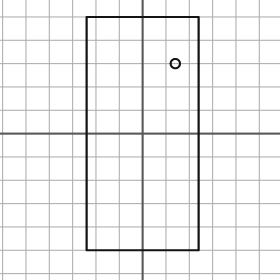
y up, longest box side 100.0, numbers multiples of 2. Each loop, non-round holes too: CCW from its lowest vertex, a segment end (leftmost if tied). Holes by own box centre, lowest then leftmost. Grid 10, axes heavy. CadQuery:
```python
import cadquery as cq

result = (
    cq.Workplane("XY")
    .moveTo(-24.0, -50.0)
    .lineTo(24.0, -50.0)
    .lineTo(24.0, 50.0)
    .lineTo(-24.0, 50.0)
    .close()
    .moveTo(14.0, 30.0)
    .circle(2.0)
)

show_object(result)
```